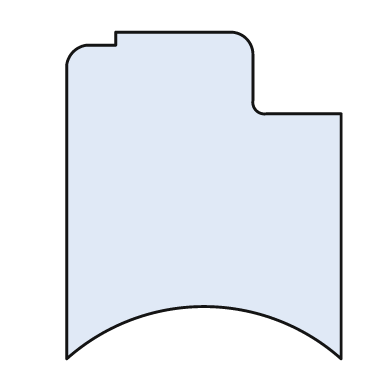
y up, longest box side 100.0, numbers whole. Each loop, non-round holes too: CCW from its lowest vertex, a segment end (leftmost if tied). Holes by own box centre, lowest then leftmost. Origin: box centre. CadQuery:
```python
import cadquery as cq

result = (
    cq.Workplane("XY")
    .moveTo(-42.0, -50.0)
    .threePointArc((0.0, -34.0), (42.0, -50.0))
    .lineTo(42.0, 25.0)
    .lineTo(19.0, 25.0)
    .threePointArc((16.0, 26.0), (15.0, 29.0))
    .lineTo(15.0, 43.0)
    .threePointArc((13.0, 48.0), (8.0, 50.0))
    .lineTo(-27.0, 50.0)
    .lineTo(-27.0, 46.0)
    .lineTo(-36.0, 46.0)
    .threePointArc((-40.0, 44.0), (-42.0, 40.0))
    .close()
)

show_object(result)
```